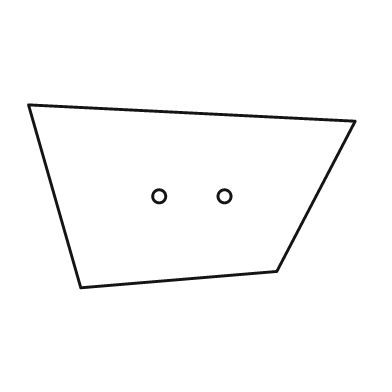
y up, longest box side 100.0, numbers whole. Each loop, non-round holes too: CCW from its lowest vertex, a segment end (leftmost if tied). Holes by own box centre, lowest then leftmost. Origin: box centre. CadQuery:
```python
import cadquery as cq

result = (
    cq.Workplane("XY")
    .moveTo(-34.0, -28.0)
    .lineTo(26.0, -23.0)
    .lineTo(50.0, 23.0)
    .lineTo(-50.0, 28.0)
    .close()
    .moveTo(-10.0, 0.0)
    .circle(2.0)
    .moveTo(10.0, 0.0)
    .circle(2.0)
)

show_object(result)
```